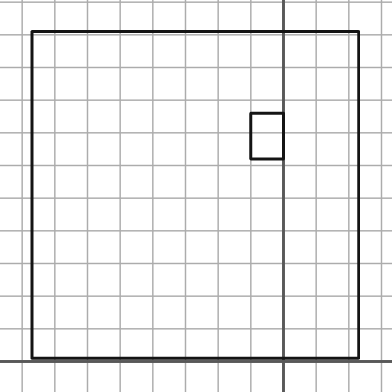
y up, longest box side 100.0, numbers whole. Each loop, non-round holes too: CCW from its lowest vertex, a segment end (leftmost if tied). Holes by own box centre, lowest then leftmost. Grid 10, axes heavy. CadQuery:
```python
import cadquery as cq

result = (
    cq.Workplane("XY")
    .moveTo(-77.0, 1.0)
    .lineTo(23.0, 1.0)
    .lineTo(23.0, 101.0)
    .lineTo(-77.0, 101.0)
    .close()
    .moveTo(-10.0, 62.0)
    .lineTo(0.0, 62.0)
    .lineTo(0.0, 76.0)
    .lineTo(-10.0, 76.0)
    .close()
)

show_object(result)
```